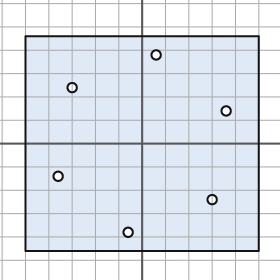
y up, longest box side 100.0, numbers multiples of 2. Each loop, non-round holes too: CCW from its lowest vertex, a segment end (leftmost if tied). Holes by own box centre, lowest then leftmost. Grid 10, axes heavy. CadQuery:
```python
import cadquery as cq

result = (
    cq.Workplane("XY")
    .moveTo(-50.0, -46.0)
    .lineTo(50.0, -46.0)
    .lineTo(50.0, 46.0)
    .lineTo(-50.0, 46.0)
    .close()
    .moveTo(-6.0, -38.0)
    .circle(2.0)
    .moveTo(30.0, -24.0)
    .circle(2.0)
    .moveTo(-36.0, -14.0)
    .circle(2.0)
    .moveTo(36.0, 14.0)
    .circle(2.0)
    .moveTo(-30.0, 24.0)
    .circle(2.0)
    .moveTo(6.0, 38.0)
    .circle(2.0)
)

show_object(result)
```